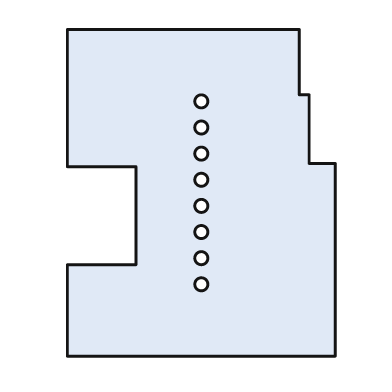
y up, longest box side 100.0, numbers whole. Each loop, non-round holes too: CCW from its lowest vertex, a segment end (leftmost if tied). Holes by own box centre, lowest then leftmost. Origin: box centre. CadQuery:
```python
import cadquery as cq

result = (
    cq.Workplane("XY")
    .moveTo(-41.0, -50.0)
    .lineTo(41.0, -50.0)
    .lineTo(41.0, 9.0)
    .lineTo(33.0, 9.0)
    .lineTo(33.0, 30.0)
    .lineTo(30.0, 30.0)
    .lineTo(30.0, 50.0)
    .lineTo(-41.0, 50.0)
    .lineTo(-41.0, 8.0)
    .lineTo(-20.0, 8.0)
    .lineTo(-20.0, -22.0)
    .lineTo(-41.0, -22.0)
    .close()
    .moveTo(0.0, -28.0)
    .circle(2.0)
    .moveTo(0.0, -20.0)
    .circle(2.0)
    .moveTo(0.0, -12.0)
    .circle(2.0)
    .moveTo(0.0, -4.0)
    .circle(2.0)
    .moveTo(0.0, 4.0)
    .circle(2.0)
    .moveTo(0.0, 12.0)
    .circle(2.0)
    .moveTo(0.0, 20.0)
    .circle(2.0)
    .moveTo(0.0, 28.0)
    .circle(2.0)
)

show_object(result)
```